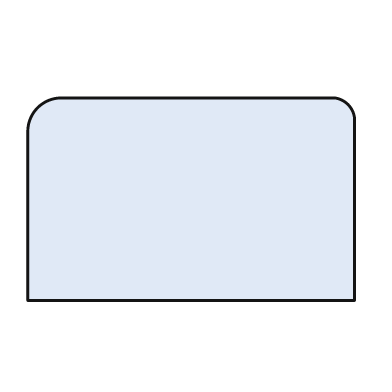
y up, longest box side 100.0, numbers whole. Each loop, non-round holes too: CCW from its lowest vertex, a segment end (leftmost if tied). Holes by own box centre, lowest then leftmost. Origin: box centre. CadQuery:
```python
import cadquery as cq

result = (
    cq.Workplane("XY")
    .moveTo(-50.0, -31.0)
    .lineTo(50.0, -31.0)
    .lineTo(50.0, 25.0)
    .threePointArc((48.0, 29.0), (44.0, 31.0))
    .lineTo(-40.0, 31.0)
    .threePointArc((-47.0, 28.0), (-50.0, 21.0))
    .close()
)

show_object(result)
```